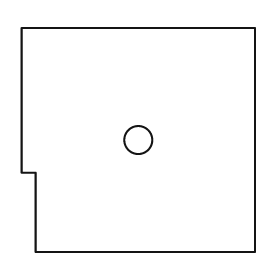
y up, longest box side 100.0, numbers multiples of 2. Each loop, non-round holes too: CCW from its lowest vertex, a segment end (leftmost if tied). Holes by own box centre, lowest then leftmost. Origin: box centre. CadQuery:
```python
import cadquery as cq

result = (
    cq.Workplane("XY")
    .moveTo(-44.0, -48.0)
    .lineTo(50.0, -48.0)
    .lineTo(50.0, 48.0)
    .lineTo(-50.0, 48.0)
    .lineTo(-50.0, -14.0)
    .lineTo(-44.0, -14.0)
    .close()
    .moveTo(0.0, 0.0)
    .circle(6.0)
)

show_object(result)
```